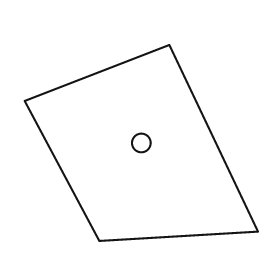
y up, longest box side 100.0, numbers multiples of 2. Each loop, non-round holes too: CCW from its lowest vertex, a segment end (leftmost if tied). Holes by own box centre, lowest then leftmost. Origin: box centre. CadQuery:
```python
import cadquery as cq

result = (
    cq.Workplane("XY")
    .moveTo(-18.0, -42.0)
    .lineTo(50.0, -38.0)
    .lineTo(12.0, 42.0)
    .lineTo(-50.0, 18.0)
    .close()
    .moveTo(0.0, 0.0)
    .circle(4.0)
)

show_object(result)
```